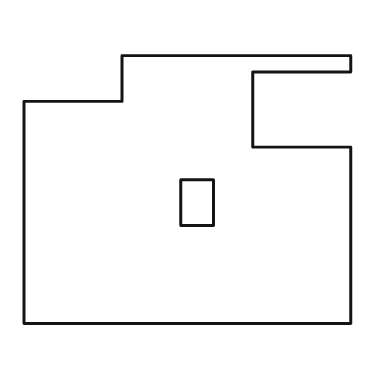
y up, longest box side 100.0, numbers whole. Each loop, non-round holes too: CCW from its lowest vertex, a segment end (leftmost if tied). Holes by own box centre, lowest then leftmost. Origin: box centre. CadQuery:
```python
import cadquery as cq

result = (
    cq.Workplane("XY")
    .moveTo(-50.0, -41.0)
    .lineTo(50.0, -41.0)
    .lineTo(50.0, 13.0)
    .lineTo(20.0, 13.0)
    .lineTo(20.0, 36.0)
    .lineTo(50.0, 36.0)
    .lineTo(50.0, 41.0)
    .lineTo(-20.0, 41.0)
    .lineTo(-20.0, 27.0)
    .lineTo(-50.0, 27.0)
    .close()
    .moveTo(-2.0, -11.0)
    .lineTo(8.0, -11.0)
    .lineTo(8.0, 3.0)
    .lineTo(-2.0, 3.0)
    .close()
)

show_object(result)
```